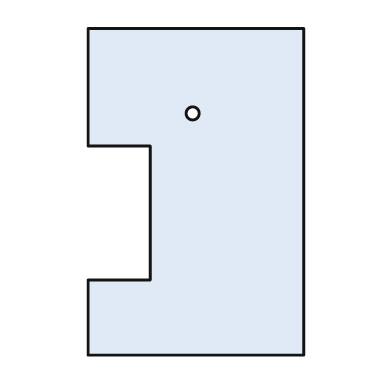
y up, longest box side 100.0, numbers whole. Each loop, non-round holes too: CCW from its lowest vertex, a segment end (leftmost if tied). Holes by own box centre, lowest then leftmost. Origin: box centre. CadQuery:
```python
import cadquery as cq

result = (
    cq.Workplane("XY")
    .moveTo(-33.0, -50.0)
    .lineTo(33.0, -50.0)
    .lineTo(33.0, 50.0)
    .lineTo(-33.0, 50.0)
    .lineTo(-33.0, 14.0)
    .lineTo(-14.0, 14.0)
    .lineTo(-14.0, -27.0)
    .lineTo(-33.0, -27.0)
    .close()
    .moveTo(-1.0, 24.0)
    .circle(2.0)
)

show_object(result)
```